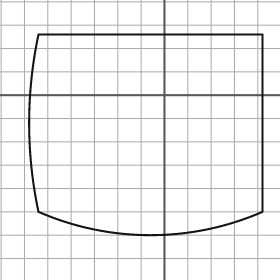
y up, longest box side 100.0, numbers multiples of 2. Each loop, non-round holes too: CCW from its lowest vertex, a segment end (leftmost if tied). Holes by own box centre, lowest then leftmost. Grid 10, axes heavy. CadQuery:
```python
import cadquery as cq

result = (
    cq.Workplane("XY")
    .moveTo(-54.0, -50.0)
    .threePointArc((-6.0, -60.0), (42.0, -50.0))
    .lineTo(42.0, 26.0)
    .lineTo(-54.0, 26.0)
    .threePointArc((-58.0, -12.0), (-54.0, -50.0))
    .close()
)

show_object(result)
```